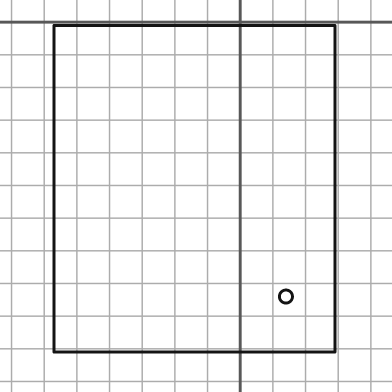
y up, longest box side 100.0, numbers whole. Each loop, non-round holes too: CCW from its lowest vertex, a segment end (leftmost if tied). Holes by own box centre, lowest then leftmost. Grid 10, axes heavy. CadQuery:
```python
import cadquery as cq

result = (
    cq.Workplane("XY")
    .moveTo(-57.0, -101.0)
    .lineTo(29.0, -101.0)
    .lineTo(29.0, -1.0)
    .lineTo(-57.0, -1.0)
    .close()
    .moveTo(14.0, -84.0)
    .circle(2.0)
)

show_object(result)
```